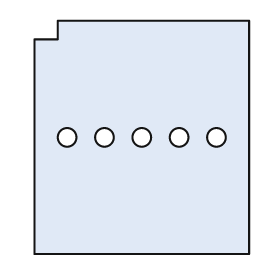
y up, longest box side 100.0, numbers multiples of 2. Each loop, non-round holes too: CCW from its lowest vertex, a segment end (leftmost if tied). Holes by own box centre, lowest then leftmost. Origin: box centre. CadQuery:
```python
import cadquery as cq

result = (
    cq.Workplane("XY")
    .moveTo(-46.0, -50.0)
    .lineTo(46.0, -50.0)
    .lineTo(46.0, 50.0)
    .lineTo(-36.0, 50.0)
    .lineTo(-36.0, 42.0)
    .lineTo(-46.0, 42.0)
    .close()
    .moveTo(-32.0, 0.0)
    .circle(4.0)
    .moveTo(-16.0, 0.0)
    .circle(4.0)
    .moveTo(0.0, 0.0)
    .circle(4.0)
    .moveTo(16.0, 0.0)
    .circle(4.0)
    .moveTo(32.0, 0.0)
    .circle(4.0)
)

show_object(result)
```